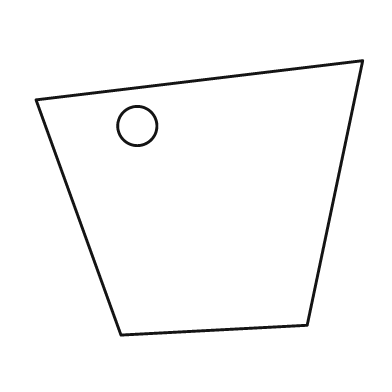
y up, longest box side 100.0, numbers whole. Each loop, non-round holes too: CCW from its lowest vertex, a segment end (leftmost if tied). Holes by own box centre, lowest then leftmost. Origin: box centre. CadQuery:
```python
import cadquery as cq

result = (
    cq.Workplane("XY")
    .moveTo(-24.0, -42.0)
    .lineTo(33.0, -39.0)
    .lineTo(50.0, 42.0)
    .lineTo(-50.0, 30.0)
    .close()
    .moveTo(-19.0, 22.0)
    .circle(6.0)
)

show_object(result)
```